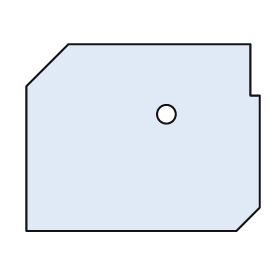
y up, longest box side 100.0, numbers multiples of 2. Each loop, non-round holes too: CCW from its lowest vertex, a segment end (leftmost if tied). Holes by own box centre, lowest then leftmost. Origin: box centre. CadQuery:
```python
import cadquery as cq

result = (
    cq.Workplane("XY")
    .moveTo(-50.0, -40.0)
    .lineTo(40.0, -40.0)
    .lineTo(50.0, -30.0)
    .lineTo(50.0, 18.0)
    .lineTo(46.0, 18.0)
    .lineTo(46.0, 40.0)
    .lineTo(-32.0, 40.0)
    .lineTo(-50.0, 22.0)
    .close()
    .moveTo(10.0, 10.0)
    .circle(4.0)
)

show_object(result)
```